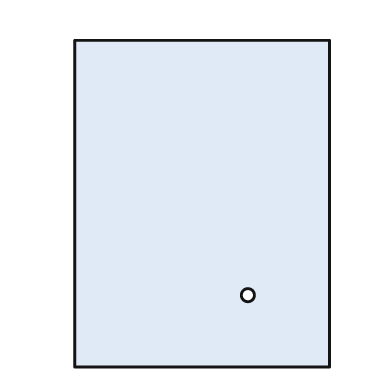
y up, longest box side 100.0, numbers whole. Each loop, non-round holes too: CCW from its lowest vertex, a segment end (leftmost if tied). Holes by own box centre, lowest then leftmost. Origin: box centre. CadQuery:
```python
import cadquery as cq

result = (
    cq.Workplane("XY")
    .moveTo(-39.0, -50.0)
    .lineTo(39.0, -50.0)
    .lineTo(39.0, 50.0)
    .lineTo(-39.0, 50.0)
    .close()
    .moveTo(14.0, -28.0)
    .circle(2.0)
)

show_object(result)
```